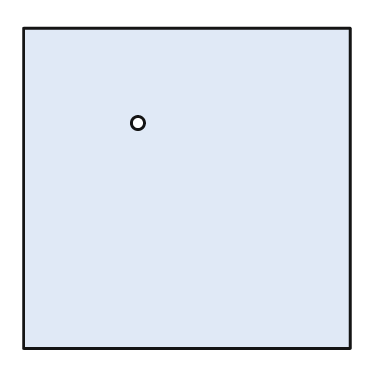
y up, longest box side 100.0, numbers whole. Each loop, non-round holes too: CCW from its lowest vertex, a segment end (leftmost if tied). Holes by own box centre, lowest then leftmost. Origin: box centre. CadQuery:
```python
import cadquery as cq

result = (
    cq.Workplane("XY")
    .moveTo(-50.0, -49.0)
    .lineTo(50.0, -49.0)
    .lineTo(50.0, 49.0)
    .lineTo(-50.0, 49.0)
    .close()
    .moveTo(-15.0, 20.0)
    .circle(2.0)
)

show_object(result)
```